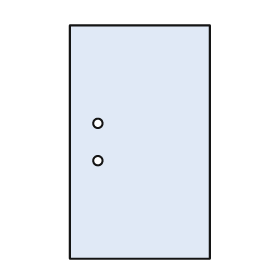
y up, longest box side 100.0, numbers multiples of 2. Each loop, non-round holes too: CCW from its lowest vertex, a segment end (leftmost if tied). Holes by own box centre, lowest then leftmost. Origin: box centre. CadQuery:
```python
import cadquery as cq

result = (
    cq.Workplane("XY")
    .moveTo(-30.0, -50.0)
    .lineTo(30.0, -50.0)
    .lineTo(30.0, 50.0)
    .lineTo(-30.0, 50.0)
    .close()
    .moveTo(-18.0, -8.0)
    .circle(2.0)
    .moveTo(-18.0, 8.0)
    .circle(2.0)
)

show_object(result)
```